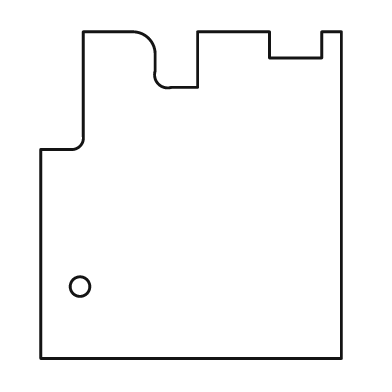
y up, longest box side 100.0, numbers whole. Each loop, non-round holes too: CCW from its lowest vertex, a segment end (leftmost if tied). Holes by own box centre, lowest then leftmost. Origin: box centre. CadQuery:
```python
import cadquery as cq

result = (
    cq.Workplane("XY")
    .moveTo(-46.0, -50.0)
    .lineTo(46.0, -50.0)
    .lineTo(46.0, 50.0)
    .lineTo(40.0, 50.0)
    .lineTo(40.0, 42.0)
    .lineTo(24.0, 42.0)
    .lineTo(24.0, 50.0)
    .lineTo(2.0, 50.0)
    .lineTo(2.0, 33.0)
    .lineTo(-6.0, 33.0)
    .threePointArc((-10.0, 34.0), (-11.0, 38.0))
    .lineTo(-11.0, 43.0)
    .threePointArc((-13.0, 48.0), (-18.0, 50.0))
    .lineTo(-33.0, 50.0)
    .lineTo(-33.0, 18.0)
    .threePointArc((-34.0, 15.0), (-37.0, 14.0))
    .lineTo(-46.0, 14.0)
    .close()
    .moveTo(-34.0, -28.0)
    .circle(3.0)
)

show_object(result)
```